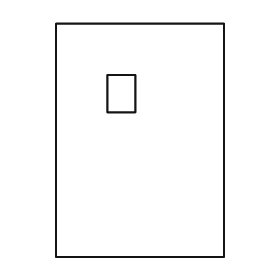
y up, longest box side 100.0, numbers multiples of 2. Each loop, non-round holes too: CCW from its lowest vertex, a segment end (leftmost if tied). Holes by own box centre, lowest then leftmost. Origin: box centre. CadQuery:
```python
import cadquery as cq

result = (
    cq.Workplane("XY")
    .moveTo(-36.0, -50.0)
    .lineTo(36.0, -50.0)
    .lineTo(36.0, 50.0)
    .lineTo(-36.0, 50.0)
    .close()
    .moveTo(-14.0, 12.0)
    .lineTo(-2.0, 12.0)
    .lineTo(-2.0, 28.0)
    .lineTo(-14.0, 28.0)
    .close()
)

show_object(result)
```